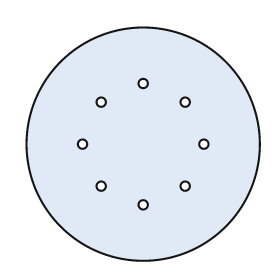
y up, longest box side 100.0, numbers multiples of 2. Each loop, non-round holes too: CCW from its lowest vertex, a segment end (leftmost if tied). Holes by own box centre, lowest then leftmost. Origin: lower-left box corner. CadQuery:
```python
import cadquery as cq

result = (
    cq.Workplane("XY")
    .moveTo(50.0, 50.0)
    .circle(50.0)
    .moveTo(50.0, 24.0)
    .circle(2.0)
    .moveTo(32.0, 32.0)
    .circle(2.0)
    .moveTo(68.0, 32.0)
    .circle(2.0)
    .moveTo(24.0, 50.0)
    .circle(2.0)
    .moveTo(76.0, 50.0)
    .circle(2.0)
    .moveTo(32.0, 68.0)
    .circle(2.0)
    .moveTo(68.0, 68.0)
    .circle(2.0)
    .moveTo(50.0, 76.0)
    .circle(2.0)
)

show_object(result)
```